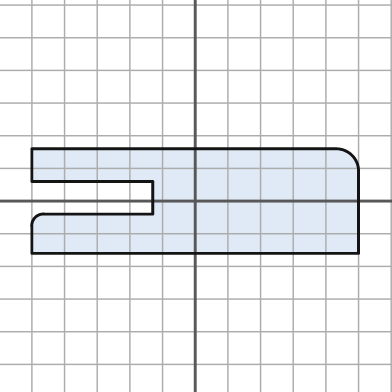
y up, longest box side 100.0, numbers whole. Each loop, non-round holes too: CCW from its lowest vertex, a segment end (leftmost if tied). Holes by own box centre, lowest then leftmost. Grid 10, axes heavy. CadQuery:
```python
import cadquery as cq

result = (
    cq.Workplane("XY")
    .moveTo(-50.0, -16.0)
    .lineTo(50.0, -16.0)
    .lineTo(50.0, 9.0)
    .threePointArc((48.0, 14.0), (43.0, 16.0))
    .lineTo(-50.0, 16.0)
    .lineTo(-50.0, 6.0)
    .lineTo(-13.0, 6.0)
    .lineTo(-13.0, -4.0)
    .lineTo(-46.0, -4.0)
    .threePointArc((-49.0, -5.0), (-50.0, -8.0))
    .close()
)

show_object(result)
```